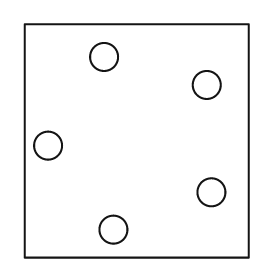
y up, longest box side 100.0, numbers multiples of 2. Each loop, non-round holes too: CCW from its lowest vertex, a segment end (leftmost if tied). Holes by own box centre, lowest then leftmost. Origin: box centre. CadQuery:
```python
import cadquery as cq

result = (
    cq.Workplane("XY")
    .moveTo(-48.0, -50.0)
    .lineTo(48.0, -50.0)
    .lineTo(48.0, 50.0)
    .lineTo(-48.0, 50.0)
    .close()
    .moveTo(-10.0, -38.0)
    .circle(6.0)
    .moveTo(32.0, -22.0)
    .circle(6.0)
    .moveTo(-38.0, -2.0)
    .circle(6.0)
    .moveTo(30.0, 24.0)
    .circle(6.0)
    .moveTo(-14.0, 36.0)
    .circle(6.0)
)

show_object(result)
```